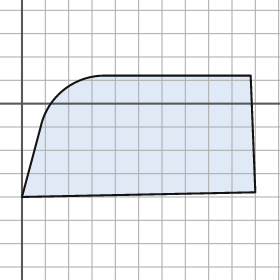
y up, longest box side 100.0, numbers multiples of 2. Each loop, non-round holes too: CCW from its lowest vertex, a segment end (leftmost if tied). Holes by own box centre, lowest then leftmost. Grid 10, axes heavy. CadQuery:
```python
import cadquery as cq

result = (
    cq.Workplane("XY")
    .moveTo(0.0, -40.0)
    .lineTo(100.0, -38.0)
    .lineTo(98.0, 12.0)
    .lineTo(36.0, 12.0)
    .threePointArc((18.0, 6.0), (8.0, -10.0))
    .close()
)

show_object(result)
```